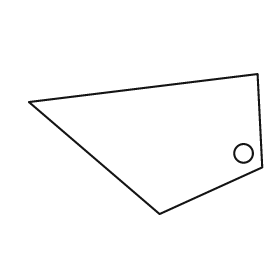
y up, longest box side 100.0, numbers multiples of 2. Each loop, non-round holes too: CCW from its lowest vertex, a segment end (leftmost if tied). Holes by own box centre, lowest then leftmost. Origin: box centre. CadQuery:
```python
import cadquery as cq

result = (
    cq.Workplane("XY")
    .moveTo(6.0, -30.0)
    .lineTo(50.0, -10.0)
    .lineTo(48.0, 30.0)
    .lineTo(-50.0, 18.0)
    .close()
    .moveTo(42.0, -4.0)
    .circle(4.0)
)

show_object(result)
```